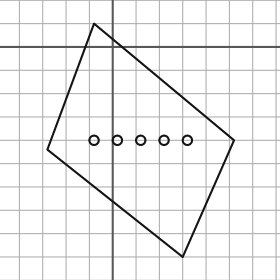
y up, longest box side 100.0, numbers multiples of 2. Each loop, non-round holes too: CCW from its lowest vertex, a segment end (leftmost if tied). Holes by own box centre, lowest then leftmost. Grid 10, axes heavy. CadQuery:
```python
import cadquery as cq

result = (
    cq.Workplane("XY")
    .moveTo(30.0, -90.0)
    .lineTo(52.0, -40.0)
    .lineTo(-8.0, 10.0)
    .lineTo(-28.0, -44.0)
    .close()
    .moveTo(-8.0, -40.0)
    .circle(2.0)
    .moveTo(2.0, -40.0)
    .circle(2.0)
    .moveTo(12.0, -40.0)
    .circle(2.0)
    .moveTo(22.0, -40.0)
    .circle(2.0)
    .moveTo(32.0, -40.0)
    .circle(2.0)
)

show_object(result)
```